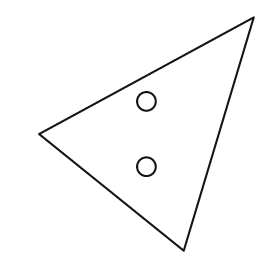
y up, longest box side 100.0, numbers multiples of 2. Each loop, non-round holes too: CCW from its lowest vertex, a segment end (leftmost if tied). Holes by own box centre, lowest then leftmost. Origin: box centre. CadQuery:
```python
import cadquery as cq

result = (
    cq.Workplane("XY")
    .moveTo(16.0, -50.0)
    .lineTo(46.0, 50.0)
    .lineTo(-46.0, 0.0)
    .close()
    .moveTo(0.0, -14.0)
    .circle(4.0)
    .moveTo(0.0, 14.0)
    .circle(4.0)
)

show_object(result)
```